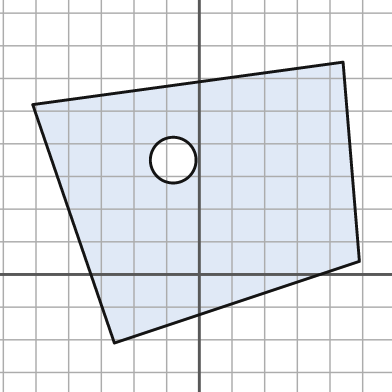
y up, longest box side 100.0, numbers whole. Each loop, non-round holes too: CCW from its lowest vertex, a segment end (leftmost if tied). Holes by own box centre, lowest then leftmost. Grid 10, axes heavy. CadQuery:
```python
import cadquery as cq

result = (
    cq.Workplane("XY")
    .moveTo(-26.0, -21.0)
    .lineTo(49.0, 4.0)
    .lineTo(44.0, 65.0)
    .lineTo(-51.0, 52.0)
    .close()
    .moveTo(-8.0, 35.0)
    .circle(7.0)
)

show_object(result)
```